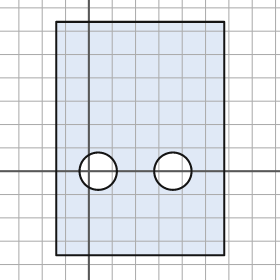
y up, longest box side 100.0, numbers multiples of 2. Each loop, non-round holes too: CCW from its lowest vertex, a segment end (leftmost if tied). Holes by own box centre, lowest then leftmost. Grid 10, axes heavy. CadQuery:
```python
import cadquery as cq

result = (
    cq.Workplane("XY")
    .moveTo(-14.0, -36.0)
    .lineTo(58.0, -36.0)
    .lineTo(58.0, 64.0)
    .lineTo(-14.0, 64.0)
    .close()
    .moveTo(4.0, 0.0)
    .circle(8.0)
    .moveTo(36.0, 0.0)
    .circle(8.0)
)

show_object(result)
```